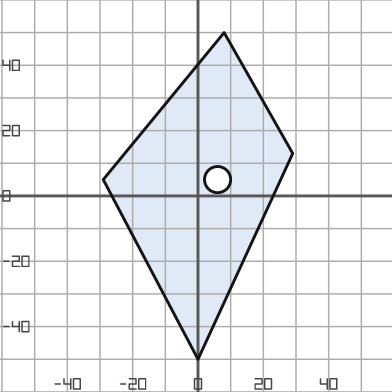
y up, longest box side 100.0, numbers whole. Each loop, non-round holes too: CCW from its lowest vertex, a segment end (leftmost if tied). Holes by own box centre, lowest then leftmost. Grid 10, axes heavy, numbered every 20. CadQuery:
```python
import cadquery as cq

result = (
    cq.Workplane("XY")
    .moveTo(0.0, -50.0)
    .lineTo(29.0, 13.0)
    .lineTo(8.0, 50.0)
    .lineTo(-29.0, 5.0)
    .close()
    .moveTo(6.0, 5.0)
    .circle(4.0)
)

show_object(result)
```